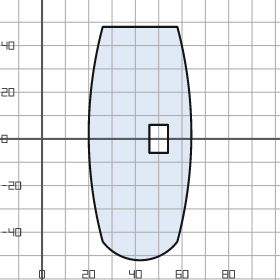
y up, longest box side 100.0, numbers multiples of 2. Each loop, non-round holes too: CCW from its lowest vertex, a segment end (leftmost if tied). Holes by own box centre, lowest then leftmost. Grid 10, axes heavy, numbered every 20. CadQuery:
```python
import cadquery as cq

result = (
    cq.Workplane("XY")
    .moveTo(26.0, -44.0)
    .threePointArc((42.0, -52.0), (58.0, -44.0))
    .threePointArc((64.0, 2.0), (58.0, 48.0))
    .lineTo(26.0, 48.0)
    .threePointArc((20.0, 2.0), (26.0, -44.0))
    .close()
    .moveTo(46.0, -6.0)
    .lineTo(54.0, -6.0)
    .lineTo(54.0, 6.0)
    .lineTo(46.0, 6.0)
    .close()
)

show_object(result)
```